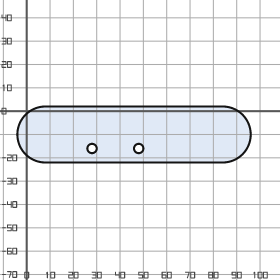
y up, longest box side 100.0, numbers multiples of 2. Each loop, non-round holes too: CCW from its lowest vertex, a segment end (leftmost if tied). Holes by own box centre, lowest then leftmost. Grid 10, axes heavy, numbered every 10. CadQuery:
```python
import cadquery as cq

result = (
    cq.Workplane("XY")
    .moveTo(8.0, -22.0)
    .lineTo(84.0, -22.0)
    .threePointArc((96.0, -10.0), (84.0, 2.0))
    .lineTo(8.0, 2.0)
    .threePointArc((-4.0, -10.0), (8.0, -22.0))
    .close()
    .moveTo(28.0, -16.0)
    .circle(2.0)
    .moveTo(48.0, -16.0)
    .circle(2.0)
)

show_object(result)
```